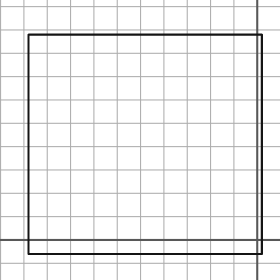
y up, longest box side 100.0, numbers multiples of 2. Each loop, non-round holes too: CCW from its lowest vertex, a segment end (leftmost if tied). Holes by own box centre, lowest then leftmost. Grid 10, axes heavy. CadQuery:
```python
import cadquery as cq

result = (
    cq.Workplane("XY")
    .moveTo(-98.0, -6.0)
    .lineTo(2.0, -6.0)
    .lineTo(2.0, 88.0)
    .lineTo(-98.0, 88.0)
    .close()
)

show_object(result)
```